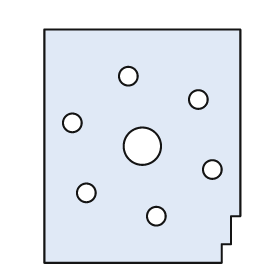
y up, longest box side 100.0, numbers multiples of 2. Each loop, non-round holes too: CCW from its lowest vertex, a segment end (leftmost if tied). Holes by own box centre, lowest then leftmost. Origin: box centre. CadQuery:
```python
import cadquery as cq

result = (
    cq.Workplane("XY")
    .moveTo(-42.0, -50.0)
    .lineTo(34.0, -50.0)
    .lineTo(34.0, -42.0)
    .lineTo(38.0, -42.0)
    .lineTo(38.0, -30.0)
    .lineTo(42.0, -30.0)
    .lineTo(42.0, 50.0)
    .lineTo(-42.0, 50.0)
    .close()
    .moveTo(6.0, -30.0)
    .circle(4.0)
    .moveTo(-24.0, -20.0)
    .circle(4.0)
    .moveTo(30.0, -10.0)
    .circle(4.0)
    .moveTo(0.0, 0.0)
    .circle(8.0)
    .moveTo(-30.0, 10.0)
    .circle(4.0)
    .moveTo(24.0, 20.0)
    .circle(4.0)
    .moveTo(-6.0, 30.0)
    .circle(4.0)
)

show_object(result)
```